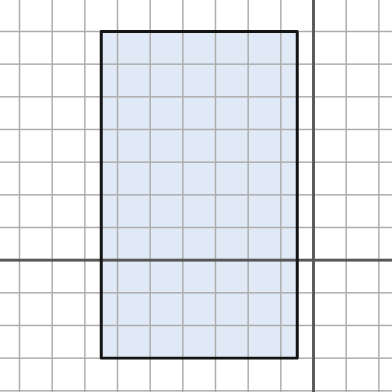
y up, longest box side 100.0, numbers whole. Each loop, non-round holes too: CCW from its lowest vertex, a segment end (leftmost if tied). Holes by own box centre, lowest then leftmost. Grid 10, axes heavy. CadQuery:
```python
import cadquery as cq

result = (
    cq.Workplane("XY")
    .moveTo(-65.0, -30.0)
    .lineTo(-5.0, -30.0)
    .lineTo(-5.0, 70.0)
    .lineTo(-65.0, 70.0)
    .close()
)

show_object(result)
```